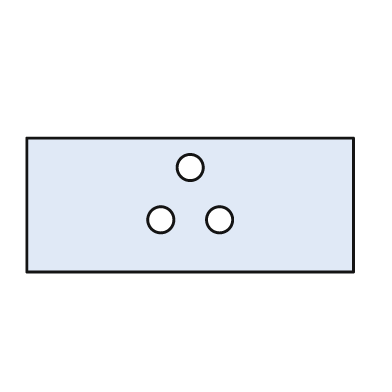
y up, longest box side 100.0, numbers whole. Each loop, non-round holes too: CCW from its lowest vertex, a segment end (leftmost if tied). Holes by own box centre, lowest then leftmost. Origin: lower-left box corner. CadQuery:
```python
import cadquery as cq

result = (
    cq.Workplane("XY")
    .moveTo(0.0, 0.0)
    .lineTo(100.0, 0.0)
    .lineTo(100.0, 41.0)
    .lineTo(0.0, 41.0)
    .close()
    .moveTo(41.0, 16.0)
    .circle(4.0)
    .moveTo(59.0, 16.0)
    .circle(4.0)
    .moveTo(50.0, 32.0)
    .circle(4.0)
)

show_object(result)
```